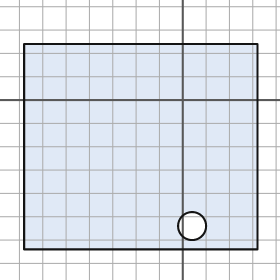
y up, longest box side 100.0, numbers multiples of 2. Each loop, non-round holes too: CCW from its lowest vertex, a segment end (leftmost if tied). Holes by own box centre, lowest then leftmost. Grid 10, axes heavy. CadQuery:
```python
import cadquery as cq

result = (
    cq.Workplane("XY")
    .moveTo(-68.0, -64.0)
    .lineTo(32.0, -64.0)
    .lineTo(32.0, 24.0)
    .lineTo(-68.0, 24.0)
    .close()
    .moveTo(4.0, -54.0)
    .circle(6.0)
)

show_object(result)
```